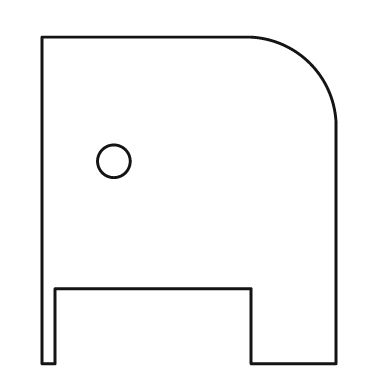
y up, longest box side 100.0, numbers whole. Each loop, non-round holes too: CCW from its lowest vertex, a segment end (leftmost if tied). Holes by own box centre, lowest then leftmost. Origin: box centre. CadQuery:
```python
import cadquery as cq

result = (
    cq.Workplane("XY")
    .moveTo(-45.0, -50.0)
    .lineTo(-41.0, -50.0)
    .lineTo(-41.0, -27.0)
    .lineTo(19.0, -27.0)
    .lineTo(19.0, -50.0)
    .lineTo(45.0, -50.0)
    .lineTo(45.0, 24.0)
    .threePointArc((37.0, 42.0), (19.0, 50.0))
    .lineTo(-45.0, 50.0)
    .close()
    .moveTo(-23.0, 12.0)
    .circle(5.0)
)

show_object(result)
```